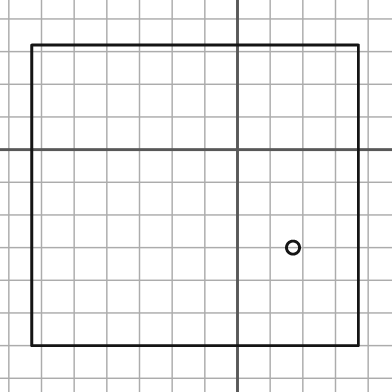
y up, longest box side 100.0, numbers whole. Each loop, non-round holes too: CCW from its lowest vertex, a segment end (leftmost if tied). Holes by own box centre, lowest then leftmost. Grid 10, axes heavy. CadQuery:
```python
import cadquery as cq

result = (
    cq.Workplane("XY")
    .moveTo(-63.0, -60.0)
    .lineTo(37.0, -60.0)
    .lineTo(37.0, 32.0)
    .lineTo(-63.0, 32.0)
    .close()
    .moveTo(17.0, -30.0)
    .circle(2.0)
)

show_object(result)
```